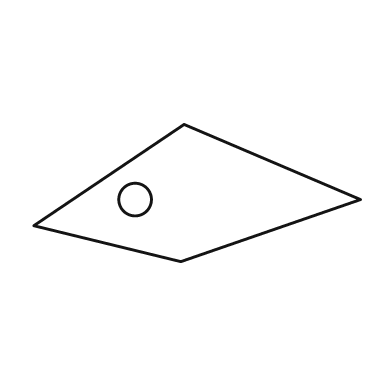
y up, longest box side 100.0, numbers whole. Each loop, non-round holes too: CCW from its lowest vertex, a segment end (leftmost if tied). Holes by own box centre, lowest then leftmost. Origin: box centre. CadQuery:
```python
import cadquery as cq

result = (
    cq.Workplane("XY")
    .moveTo(-5.0, -21.0)
    .lineTo(50.0, -2.0)
    .lineTo(-4.0, 21.0)
    .lineTo(-50.0, -10.0)
    .close()
    .moveTo(-19.0, -2.0)
    .circle(5.0)
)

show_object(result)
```